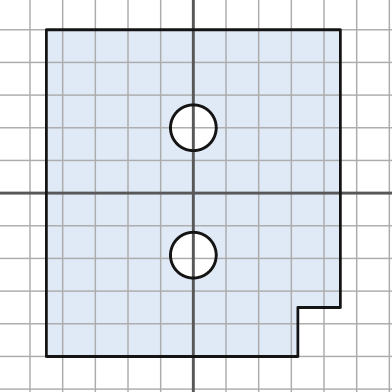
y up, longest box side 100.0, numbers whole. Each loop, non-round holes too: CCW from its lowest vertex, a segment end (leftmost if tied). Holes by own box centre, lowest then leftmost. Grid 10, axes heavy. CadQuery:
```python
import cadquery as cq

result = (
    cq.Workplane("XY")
    .moveTo(-45.0, -50.0)
    .lineTo(32.0, -50.0)
    .lineTo(32.0, -35.0)
    .lineTo(45.0, -35.0)
    .lineTo(45.0, 50.0)
    .lineTo(-45.0, 50.0)
    .close()
    .moveTo(0.0, -19.0)
    .circle(7.0)
    .moveTo(0.0, 20.0)
    .circle(7.0)
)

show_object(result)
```